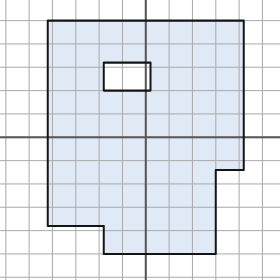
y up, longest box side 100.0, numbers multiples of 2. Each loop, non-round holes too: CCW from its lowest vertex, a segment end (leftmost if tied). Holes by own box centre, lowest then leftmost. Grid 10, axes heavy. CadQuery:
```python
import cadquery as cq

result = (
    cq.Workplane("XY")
    .moveTo(-18.0, -50.0)
    .lineTo(30.0, -50.0)
    .lineTo(30.0, -14.0)
    .lineTo(42.0, -14.0)
    .lineTo(42.0, 50.0)
    .lineTo(-42.0, 50.0)
    .lineTo(-42.0, -38.0)
    .lineTo(-18.0, -38.0)
    .close()
    .moveTo(-18.0, 20.0)
    .lineTo(2.0, 20.0)
    .lineTo(2.0, 32.0)
    .lineTo(-18.0, 32.0)
    .close()
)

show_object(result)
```